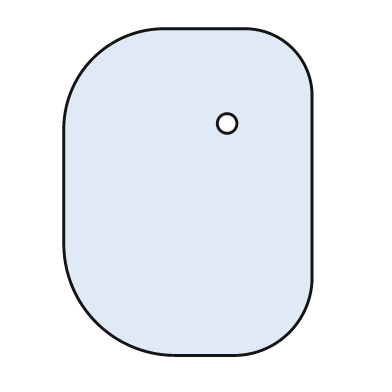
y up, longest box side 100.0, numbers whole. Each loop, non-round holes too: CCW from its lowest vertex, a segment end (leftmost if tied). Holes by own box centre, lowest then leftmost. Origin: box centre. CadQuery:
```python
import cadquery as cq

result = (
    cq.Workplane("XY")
    .moveTo(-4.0, -50.0)
    .lineTo(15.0, -50.0)
    .threePointArc((31.0, -43.0), (38.0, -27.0))
    .lineTo(38.0, 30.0)
    .threePointArc((32.0, 44.0), (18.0, 50.0))
    .lineTo(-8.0, 50.0)
    .threePointArc((-29.0, 41.0), (-38.0, 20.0))
    .lineTo(-38.0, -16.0)
    .threePointArc((-28.0, -40.0), (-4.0, -50.0))
    .close()
    .moveTo(12.0, 21.0)
    .circle(3.0)
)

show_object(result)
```